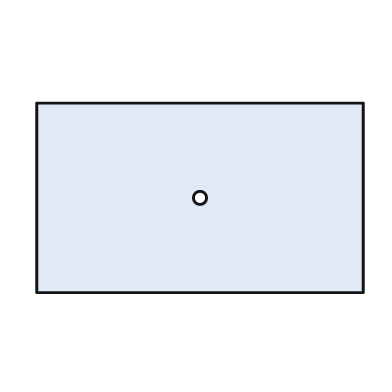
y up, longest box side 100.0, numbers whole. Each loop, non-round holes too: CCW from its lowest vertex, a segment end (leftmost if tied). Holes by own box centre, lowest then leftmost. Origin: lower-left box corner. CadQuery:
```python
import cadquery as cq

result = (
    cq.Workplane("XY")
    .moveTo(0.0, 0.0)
    .lineTo(100.0, 0.0)
    .lineTo(100.0, 58.0)
    .lineTo(0.0, 58.0)
    .close()
    .moveTo(50.0, 29.0)
    .circle(2.0)
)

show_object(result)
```